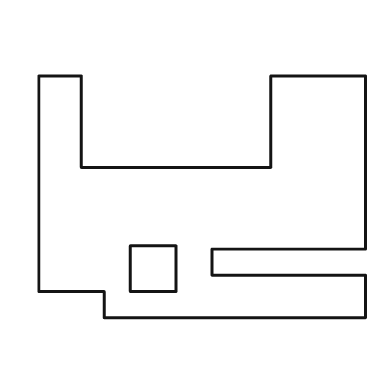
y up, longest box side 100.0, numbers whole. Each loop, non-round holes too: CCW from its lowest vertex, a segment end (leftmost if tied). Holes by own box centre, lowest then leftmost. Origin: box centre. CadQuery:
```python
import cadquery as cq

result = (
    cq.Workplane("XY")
    .moveTo(-30.0, -37.0)
    .lineTo(50.0, -37.0)
    .lineTo(50.0, -24.0)
    .lineTo(3.0, -24.0)
    .lineTo(3.0, -16.0)
    .lineTo(50.0, -16.0)
    .lineTo(50.0, 37.0)
    .lineTo(21.0, 37.0)
    .lineTo(21.0, 9.0)
    .lineTo(-37.0, 9.0)
    .lineTo(-37.0, 37.0)
    .lineTo(-50.0, 37.0)
    .lineTo(-50.0, -29.0)
    .lineTo(-30.0, -29.0)
    .close()
    .moveTo(-22.0, -29.0)
    .lineTo(-8.0, -29.0)
    .lineTo(-8.0, -15.0)
    .lineTo(-22.0, -15.0)
    .close()
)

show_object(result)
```